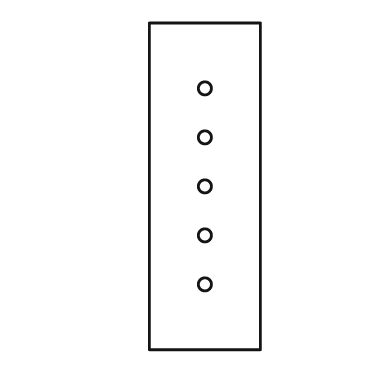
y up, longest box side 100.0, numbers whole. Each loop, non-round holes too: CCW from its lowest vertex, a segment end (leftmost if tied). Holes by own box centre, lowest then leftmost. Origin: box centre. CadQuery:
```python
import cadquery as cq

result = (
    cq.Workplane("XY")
    .moveTo(-17.0, -50.0)
    .lineTo(17.0, -50.0)
    .lineTo(17.0, 50.0)
    .lineTo(-17.0, 50.0)
    .close()
    .moveTo(0.0, -30.0)
    .circle(2.0)
    .moveTo(0.0, -15.0)
    .circle(2.0)
    .moveTo(0.0, 0.0)
    .circle(2.0)
    .moveTo(0.0, 15.0)
    .circle(2.0)
    .moveTo(0.0, 30.0)
    .circle(2.0)
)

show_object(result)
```